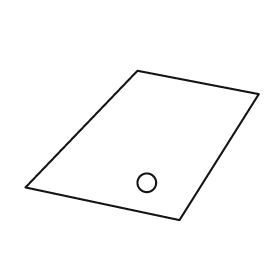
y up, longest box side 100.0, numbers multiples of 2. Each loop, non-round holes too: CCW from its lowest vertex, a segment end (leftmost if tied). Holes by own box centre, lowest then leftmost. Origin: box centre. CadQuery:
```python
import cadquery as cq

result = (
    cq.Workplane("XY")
    .moveTo(16.0, -32.0)
    .lineTo(50.0, 22.0)
    .lineTo(-2.0, 32.0)
    .lineTo(-50.0, -18.0)
    .close()
    .moveTo(2.0, -16.0)
    .circle(4.0)
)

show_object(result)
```